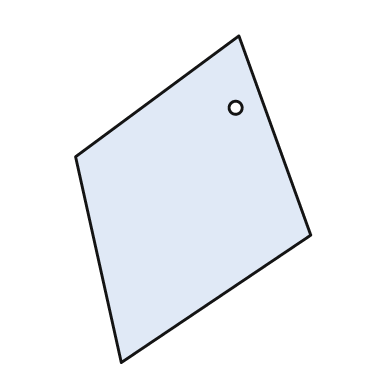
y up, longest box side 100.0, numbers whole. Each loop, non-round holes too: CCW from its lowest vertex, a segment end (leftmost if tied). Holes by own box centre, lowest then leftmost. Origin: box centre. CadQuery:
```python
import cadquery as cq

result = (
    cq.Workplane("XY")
    .moveTo(-22.0, -50.0)
    .lineTo(36.0, -11.0)
    .lineTo(14.0, 50.0)
    .lineTo(-36.0, 13.0)
    .close()
    .moveTo(13.0, 28.0)
    .circle(2.0)
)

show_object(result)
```